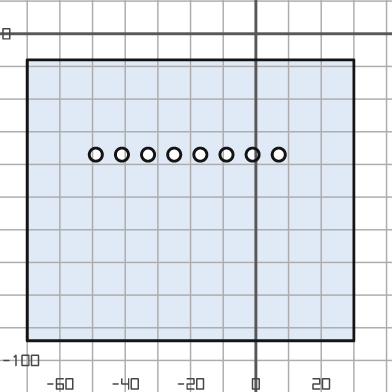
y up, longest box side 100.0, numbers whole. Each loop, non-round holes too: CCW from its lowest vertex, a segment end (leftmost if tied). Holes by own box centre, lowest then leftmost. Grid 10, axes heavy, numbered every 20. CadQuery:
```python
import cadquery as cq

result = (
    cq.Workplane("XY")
    .moveTo(-70.0, -94.0)
    .lineTo(30.0, -94.0)
    .lineTo(30.0, -8.0)
    .lineTo(-70.0, -8.0)
    .close()
    .moveTo(-49.0, -37.0)
    .circle(2.0)
    .moveTo(-41.0, -37.0)
    .circle(2.0)
    .moveTo(-33.0, -37.0)
    .circle(2.0)
    .moveTo(-25.0, -37.0)
    .circle(2.0)
    .moveTo(-17.0, -37.0)
    .circle(2.0)
    .moveTo(-9.0, -37.0)
    .circle(2.0)
    .moveTo(-1.0, -37.0)
    .circle(2.0)
    .moveTo(7.0, -37.0)
    .circle(2.0)
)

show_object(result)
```